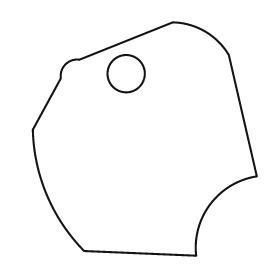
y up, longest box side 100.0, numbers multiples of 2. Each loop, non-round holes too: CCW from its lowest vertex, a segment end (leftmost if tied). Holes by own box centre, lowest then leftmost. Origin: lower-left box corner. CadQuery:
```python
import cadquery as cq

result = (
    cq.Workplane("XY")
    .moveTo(70.0, 0.0)
    .threePointArc((76.0, 22.0), (96.0, 34.0))
    .lineTo(84.0, 86.0)
    .threePointArc((74.0, 96.0), (60.0, 100.0))
    .lineTo(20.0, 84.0)
    .threePointArc((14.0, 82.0), (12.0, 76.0))
    .lineTo(0.0, 54.0)
    .threePointArc((6.0, 26.0), (22.0, 2.0))
    .close()
    .moveTo(40.0, 78.0)
    .circle(8.0)
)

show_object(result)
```